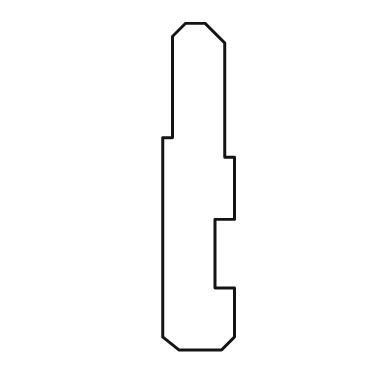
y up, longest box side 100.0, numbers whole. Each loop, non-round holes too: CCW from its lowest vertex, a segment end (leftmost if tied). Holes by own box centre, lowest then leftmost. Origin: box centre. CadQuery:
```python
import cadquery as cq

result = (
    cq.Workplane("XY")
    .moveTo(-6.0, -50.0)
    .lineTo(7.0, -50.0)
    .lineTo(11.0, -46.0)
    .lineTo(11.0, -31.0)
    .lineTo(5.0, -31.0)
    .lineTo(5.0, -10.0)
    .lineTo(11.0, -10.0)
    .lineTo(11.0, 9.0)
    .lineTo(8.0, 9.0)
    .lineTo(8.0, 44.0)
    .lineTo(2.0, 50.0)
    .lineTo(-4.0, 50.0)
    .lineTo(-8.0, 46.0)
    .lineTo(-8.0, 15.0)
    .lineTo(-11.0, 15.0)
    .lineTo(-11.0, -46.0)
    .close()
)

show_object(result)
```